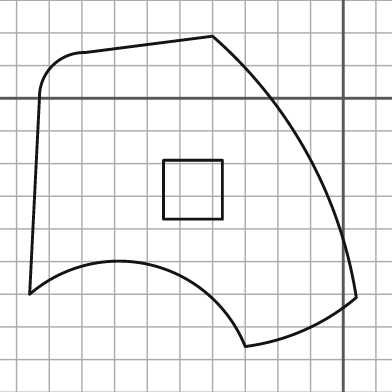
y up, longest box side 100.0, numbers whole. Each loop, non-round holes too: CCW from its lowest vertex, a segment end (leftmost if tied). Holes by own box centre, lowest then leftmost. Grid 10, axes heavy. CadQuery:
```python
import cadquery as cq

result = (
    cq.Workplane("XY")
    .moveTo(-30.0, -76.0)
    .threePointArc((-12.0, -71.0), (4.0, -61.0))
    .threePointArc((-11.0, -17.0), (-40.0, 19.0))
    .lineTo(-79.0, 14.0)
    .threePointArc((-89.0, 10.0), (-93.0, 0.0))
    .lineTo(-96.0, -60.0)
    .threePointArc((-59.0, -51.0), (-30.0, -76.0))
    .close()
    .moveTo(-55.0, -37.0)
    .lineTo(-37.0, -37.0)
    .lineTo(-37.0, -19.0)
    .lineTo(-55.0, -19.0)
    .close()
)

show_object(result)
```